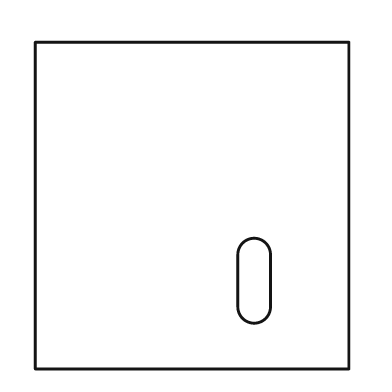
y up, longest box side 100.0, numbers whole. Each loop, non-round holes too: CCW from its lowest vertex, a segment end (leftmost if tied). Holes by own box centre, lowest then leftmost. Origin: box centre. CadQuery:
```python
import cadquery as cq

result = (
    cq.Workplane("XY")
    .moveTo(-48.0, -50.0)
    .lineTo(48.0, -50.0)
    .lineTo(48.0, 50.0)
    .lineTo(-48.0, 50.0)
    .close()
    .moveTo(14.0, -31.0)
    .threePointArc((19.0, -36.0), (24.0, -31.0))
    .lineTo(24.0, -15.0)
    .threePointArc((19.0, -10.0), (14.0, -15.0))
    .close()
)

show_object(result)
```